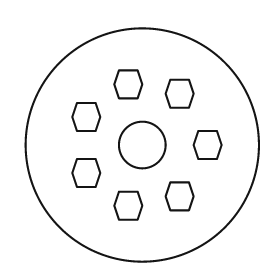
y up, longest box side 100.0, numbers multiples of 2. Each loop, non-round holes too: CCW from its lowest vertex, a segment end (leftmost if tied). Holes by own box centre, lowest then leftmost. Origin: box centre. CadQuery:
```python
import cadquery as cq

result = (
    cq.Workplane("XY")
    .moveTo(0.0, 0.0)
    .circle(50.0)
    .moveTo(-10.0, -32.0)
    .lineTo(-2.0, -32.0)
    .lineTo(0.0, -26.0)
    .lineTo(-2.0, -20.0)
    .lineTo(-10.0, -20.0)
    .lineTo(-12.0, -26.0)
    .close()
    .moveTo(12.0, -28.0)
    .lineTo(20.0, -28.0)
    .lineTo(22.0, -22.0)
    .lineTo(20.0, -16.0)
    .lineTo(12.0, -16.0)
    .lineTo(10.0, -22.0)
    .close()
    .moveTo(-28.0, -18.0)
    .lineTo(-20.0, -18.0)
    .lineTo(-18.0, -12.0)
    .lineTo(-20.0, -6.0)
    .lineTo(-28.0, -6.0)
    .lineTo(-30.0, -12.0)
    .close()
    .moveTo(0.0, 0.0)
    .circle(10.0)
    .moveTo(24.0, -6.0)
    .lineTo(32.0, -6.0)
    .lineTo(34.0, 0.0)
    .lineTo(32.0, 6.0)
    .lineTo(24.0, 6.0)
    .lineTo(22.0, 0.0)
    .close()
    .moveTo(-28.0, 6.0)
    .lineTo(-20.0, 6.0)
    .lineTo(-18.0, 12.0)
    .lineTo(-20.0, 18.0)
    .lineTo(-28.0, 18.0)
    .lineTo(-30.0, 12.0)
    .close()
    .moveTo(12.0, 16.0)
    .lineTo(20.0, 16.0)
    .lineTo(22.0, 22.0)
    .lineTo(20.0, 28.0)
    .lineTo(12.0, 28.0)
    .lineTo(10.0, 22.0)
    .close()
    .moveTo(-10.0, 20.0)
    .lineTo(-2.0, 20.0)
    .lineTo(0.0, 26.0)
    .lineTo(-2.0, 32.0)
    .lineTo(-10.0, 32.0)
    .lineTo(-12.0, 26.0)
    .close()
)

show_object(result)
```